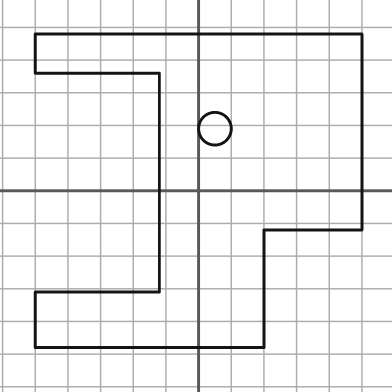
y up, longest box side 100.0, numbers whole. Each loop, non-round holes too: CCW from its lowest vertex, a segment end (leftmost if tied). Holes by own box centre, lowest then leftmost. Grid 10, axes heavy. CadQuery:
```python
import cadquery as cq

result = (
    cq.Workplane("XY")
    .moveTo(-50.0, -48.0)
    .lineTo(20.0, -48.0)
    .lineTo(20.0, -12.0)
    .lineTo(50.0, -12.0)
    .lineTo(50.0, 48.0)
    .lineTo(-50.0, 48.0)
    .lineTo(-50.0, 36.0)
    .lineTo(-12.0, 36.0)
    .lineTo(-12.0, -31.0)
    .lineTo(-50.0, -31.0)
    .close()
    .moveTo(5.0, 19.0)
    .circle(5.0)
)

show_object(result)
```